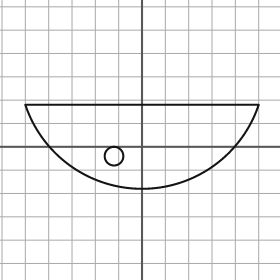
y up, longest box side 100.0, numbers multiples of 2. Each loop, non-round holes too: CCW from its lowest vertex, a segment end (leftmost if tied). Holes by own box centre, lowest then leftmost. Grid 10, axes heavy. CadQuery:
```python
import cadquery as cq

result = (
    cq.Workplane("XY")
    .moveTo(-50.0, 18.0)
    .threePointArc((0.0, -18.0), (50.0, 18.0))
    .close()
    .moveTo(-12.0, -4.0)
    .circle(4.0)
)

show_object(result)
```